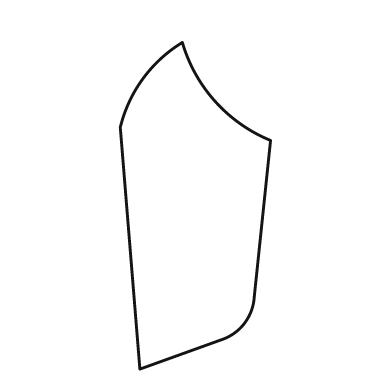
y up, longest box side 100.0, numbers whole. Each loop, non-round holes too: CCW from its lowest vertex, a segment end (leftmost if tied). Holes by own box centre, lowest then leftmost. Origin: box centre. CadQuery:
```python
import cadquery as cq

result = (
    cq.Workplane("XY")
    .moveTo(-17.0, -50.0)
    .lineTo(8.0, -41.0)
    .threePointArc((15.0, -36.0), (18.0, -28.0))
    .lineTo(23.0, 20.0)
    .threePointArc((6.0, 32.0), (-4.0, 50.0))
    .threePointArc((-16.0, 39.0), (-23.0, 24.0))
    .close()
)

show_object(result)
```